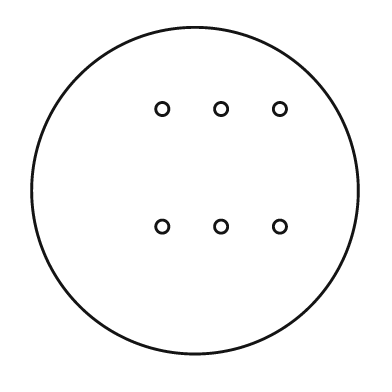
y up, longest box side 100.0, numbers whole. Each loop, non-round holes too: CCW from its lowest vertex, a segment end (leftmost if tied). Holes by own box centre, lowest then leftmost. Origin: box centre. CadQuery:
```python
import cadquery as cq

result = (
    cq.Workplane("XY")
    .moveTo(0.0, 0.0)
    .circle(50.0)
    .moveTo(-10.0, -11.0)
    .circle(2.0)
    .moveTo(8.0, -11.0)
    .circle(2.0)
    .moveTo(26.0, -11.0)
    .circle(2.0)
    .moveTo(-10.0, 25.0)
    .circle(2.0)
    .moveTo(8.0, 25.0)
    .circle(2.0)
    .moveTo(26.0, 25.0)
    .circle(2.0)
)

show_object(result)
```